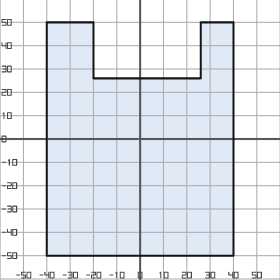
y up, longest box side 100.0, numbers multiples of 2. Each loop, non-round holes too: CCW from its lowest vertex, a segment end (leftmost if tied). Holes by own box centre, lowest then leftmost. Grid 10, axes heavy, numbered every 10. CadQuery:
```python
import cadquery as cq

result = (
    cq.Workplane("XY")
    .moveTo(-40.0, -50.0)
    .lineTo(40.0, -50.0)
    .lineTo(40.0, 50.0)
    .lineTo(26.0, 50.0)
    .lineTo(26.0, 26.0)
    .lineTo(-20.0, 26.0)
    .lineTo(-20.0, 50.0)
    .lineTo(-40.0, 50.0)
    .close()
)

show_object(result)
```